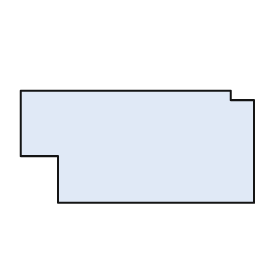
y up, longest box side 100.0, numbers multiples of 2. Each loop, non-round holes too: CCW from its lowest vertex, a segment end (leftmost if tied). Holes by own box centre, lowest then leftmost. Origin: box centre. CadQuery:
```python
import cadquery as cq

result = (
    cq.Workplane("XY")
    .moveTo(-34.0, -24.0)
    .lineTo(50.0, -24.0)
    .lineTo(50.0, 20.0)
    .lineTo(40.0, 20.0)
    .lineTo(40.0, 24.0)
    .lineTo(-50.0, 24.0)
    .lineTo(-50.0, -4.0)
    .lineTo(-34.0, -4.0)
    .close()
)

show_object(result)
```